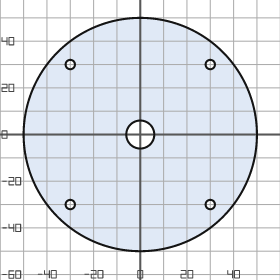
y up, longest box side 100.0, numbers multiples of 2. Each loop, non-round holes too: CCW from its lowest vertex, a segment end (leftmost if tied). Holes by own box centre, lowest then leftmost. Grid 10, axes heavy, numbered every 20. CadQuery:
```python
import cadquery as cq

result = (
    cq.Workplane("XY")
    .moveTo(0.0, 0.0)
    .circle(50.0)
    .moveTo(-30.0, -30.0)
    .circle(2.0)
    .moveTo(30.0, -30.0)
    .circle(2.0)
    .moveTo(0.0, 0.0)
    .circle(6.0)
    .moveTo(-30.0, 30.0)
    .circle(2.0)
    .moveTo(30.0, 30.0)
    .circle(2.0)
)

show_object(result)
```